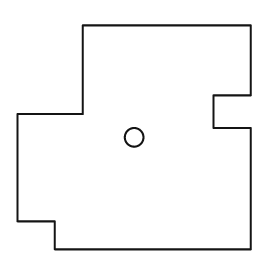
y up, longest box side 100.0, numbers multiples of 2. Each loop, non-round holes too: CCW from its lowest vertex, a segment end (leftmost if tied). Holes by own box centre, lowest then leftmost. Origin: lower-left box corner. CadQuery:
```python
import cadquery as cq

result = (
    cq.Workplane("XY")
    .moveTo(16.0, 0.0)
    .lineTo(100.0, 0.0)
    .lineTo(100.0, 52.0)
    .lineTo(84.0, 52.0)
    .lineTo(84.0, 66.0)
    .lineTo(100.0, 66.0)
    .lineTo(100.0, 96.0)
    .lineTo(28.0, 96.0)
    .lineTo(28.0, 58.0)
    .lineTo(0.0, 58.0)
    .lineTo(0.0, 12.0)
    .lineTo(16.0, 12.0)
    .close()
    .moveTo(50.0, 48.0)
    .circle(4.0)
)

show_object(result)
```